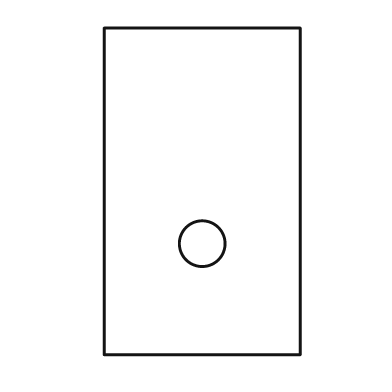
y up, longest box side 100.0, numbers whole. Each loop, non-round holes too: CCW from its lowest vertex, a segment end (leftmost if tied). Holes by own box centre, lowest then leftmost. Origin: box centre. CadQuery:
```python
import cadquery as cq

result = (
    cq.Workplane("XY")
    .moveTo(-30.0, -50.0)
    .lineTo(30.0, -50.0)
    .lineTo(30.0, 50.0)
    .lineTo(-30.0, 50.0)
    .close()
    .moveTo(0.0, -16.0)
    .circle(7.0)
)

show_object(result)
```